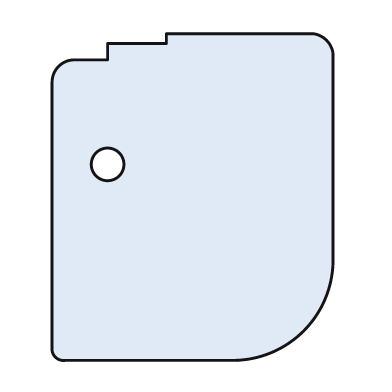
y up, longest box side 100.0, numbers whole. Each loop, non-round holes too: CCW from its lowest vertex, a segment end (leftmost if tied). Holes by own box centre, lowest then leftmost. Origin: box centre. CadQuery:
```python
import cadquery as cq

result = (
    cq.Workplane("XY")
    .moveTo(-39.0, -50.0)
    .lineTo(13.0, -50.0)
    .threePointArc((34.0, -41.0), (43.0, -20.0))
    .lineTo(43.0, 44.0)
    .threePointArc((41.0, 48.0), (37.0, 50.0))
    .lineTo(-8.0, 50.0)
    .lineTo(-8.0, 47.0)
    .lineTo(-26.0, 47.0)
    .lineTo(-26.0, 42.0)
    .lineTo(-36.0, 42.0)
    .threePointArc((-41.0, 40.0), (-43.0, 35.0))
    .lineTo(-43.0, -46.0)
    .threePointArc((-42.0, -49.0), (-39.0, -50.0))
    .close()
    .moveTo(-26.0, 10.0)
    .circle(5.0)
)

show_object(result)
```